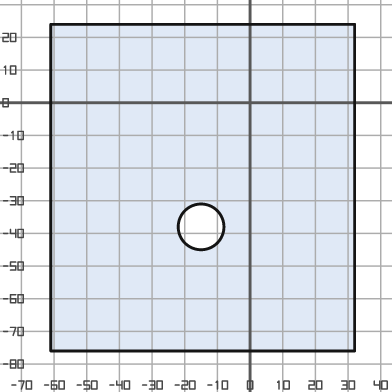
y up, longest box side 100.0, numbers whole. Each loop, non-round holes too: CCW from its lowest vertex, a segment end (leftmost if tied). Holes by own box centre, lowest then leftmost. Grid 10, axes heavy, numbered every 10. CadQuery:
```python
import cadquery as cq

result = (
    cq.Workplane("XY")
    .moveTo(-61.0, -76.0)
    .lineTo(32.0, -76.0)
    .lineTo(32.0, 24.0)
    .lineTo(-61.0, 24.0)
    .close()
    .moveTo(-15.0, -38.0)
    .circle(7.0)
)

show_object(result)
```